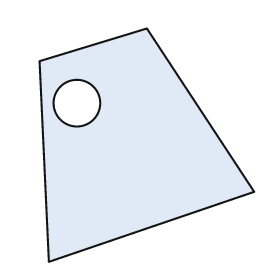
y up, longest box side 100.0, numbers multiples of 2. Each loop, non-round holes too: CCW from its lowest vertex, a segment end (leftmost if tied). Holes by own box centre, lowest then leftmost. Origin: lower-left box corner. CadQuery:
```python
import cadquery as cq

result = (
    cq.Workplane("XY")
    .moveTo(4.0, 0.0)
    .lineTo(92.0, 30.0)
    .lineTo(46.0, 100.0)
    .lineTo(0.0, 86.0)
    .close()
    .moveTo(16.0, 68.0)
    .circle(10.0)
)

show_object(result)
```